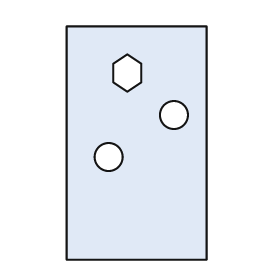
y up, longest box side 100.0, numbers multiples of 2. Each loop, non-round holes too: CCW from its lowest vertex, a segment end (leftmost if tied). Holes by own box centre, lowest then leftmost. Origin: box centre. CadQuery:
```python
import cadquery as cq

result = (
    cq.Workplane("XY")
    .moveTo(-30.0, -50.0)
    .lineTo(30.0, -50.0)
    .lineTo(30.0, 50.0)
    .lineTo(-30.0, 50.0)
    .close()
    .moveTo(-12.0, -6.0)
    .circle(6.0)
    .moveTo(16.0, 12.0)
    .circle(6.0)
    .moveTo(-4.0, 22.0)
    .lineTo(2.0, 26.0)
    .lineTo(2.0, 34.0)
    .lineTo(-4.0, 38.0)
    .lineTo(-10.0, 34.0)
    .lineTo(-10.0, 26.0)
    .close()
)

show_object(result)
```